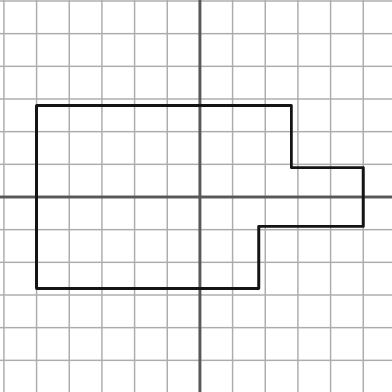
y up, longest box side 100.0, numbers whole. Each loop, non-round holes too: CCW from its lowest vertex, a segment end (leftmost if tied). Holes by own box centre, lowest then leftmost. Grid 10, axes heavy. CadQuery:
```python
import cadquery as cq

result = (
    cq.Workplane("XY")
    .moveTo(-50.0, -28.0)
    .lineTo(18.0, -28.0)
    .lineTo(18.0, -9.0)
    .lineTo(50.0, -9.0)
    .lineTo(50.0, 9.0)
    .lineTo(28.0, 9.0)
    .lineTo(28.0, 28.0)
    .lineTo(-50.0, 28.0)
    .close()
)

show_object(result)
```